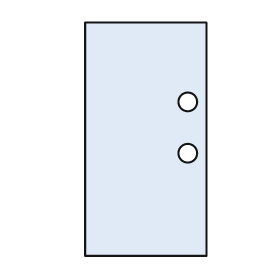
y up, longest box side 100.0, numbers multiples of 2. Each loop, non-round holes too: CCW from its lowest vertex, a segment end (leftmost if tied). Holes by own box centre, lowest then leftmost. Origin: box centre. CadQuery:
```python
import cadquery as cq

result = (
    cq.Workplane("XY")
    .moveTo(-26.0, -50.0)
    .lineTo(26.0, -50.0)
    .lineTo(26.0, 50.0)
    .lineTo(-26.0, 50.0)
    .close()
    .moveTo(18.0, -6.0)
    .circle(4.0)
    .moveTo(18.0, 16.0)
    .circle(4.0)
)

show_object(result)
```